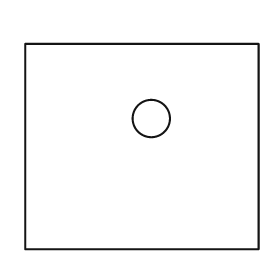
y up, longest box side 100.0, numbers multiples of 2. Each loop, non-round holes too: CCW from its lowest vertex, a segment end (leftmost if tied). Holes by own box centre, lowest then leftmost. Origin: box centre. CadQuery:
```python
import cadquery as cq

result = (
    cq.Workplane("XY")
    .moveTo(-50.0, -44.0)
    .lineTo(50.0, -44.0)
    .lineTo(50.0, 44.0)
    .lineTo(-50.0, 44.0)
    .close()
    .moveTo(4.0, 12.0)
    .circle(8.0)
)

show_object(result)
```